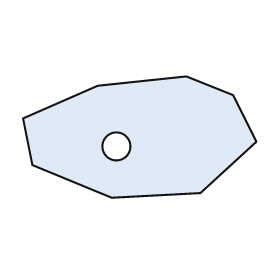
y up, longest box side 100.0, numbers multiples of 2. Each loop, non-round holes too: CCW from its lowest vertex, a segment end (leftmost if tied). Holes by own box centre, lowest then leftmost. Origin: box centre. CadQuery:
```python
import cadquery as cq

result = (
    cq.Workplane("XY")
    .moveTo(-12.0, -26.0)
    .lineTo(26.0, -24.0)
    .lineTo(50.0, -2.0)
    .lineTo(40.0, 18.0)
    .lineTo(20.0, 26.0)
    .lineTo(-18.0, 22.0)
    .lineTo(-50.0, 8.0)
    .lineTo(-46.0, -12.0)
    .close()
    .moveTo(-10.0, -4.0)
    .circle(6.0)
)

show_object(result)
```